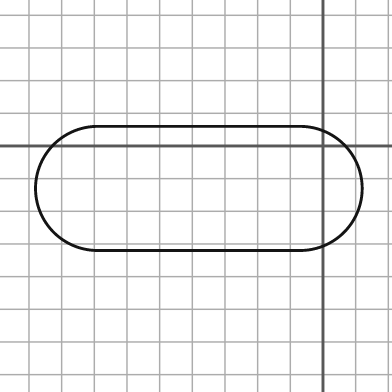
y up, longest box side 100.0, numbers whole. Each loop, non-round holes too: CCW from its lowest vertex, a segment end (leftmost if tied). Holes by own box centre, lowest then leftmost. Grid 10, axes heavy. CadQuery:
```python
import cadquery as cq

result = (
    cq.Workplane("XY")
    .moveTo(-69.0, -32.0)
    .lineTo(-7.0, -32.0)
    .threePointArc((12.0, -13.0), (-7.0, 6.0))
    .lineTo(-69.0, 6.0)
    .threePointArc((-88.0, -13.0), (-69.0, -32.0))
    .close()
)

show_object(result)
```